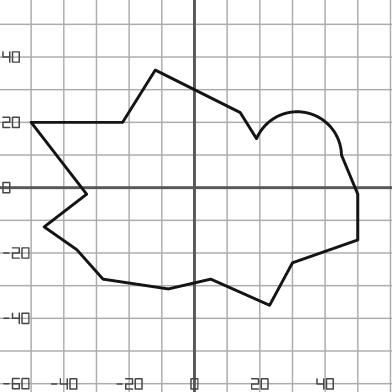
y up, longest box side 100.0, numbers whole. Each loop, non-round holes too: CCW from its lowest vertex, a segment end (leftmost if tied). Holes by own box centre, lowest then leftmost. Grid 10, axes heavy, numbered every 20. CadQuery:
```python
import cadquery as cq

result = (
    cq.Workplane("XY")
    .moveTo(23.0, -36.0)
    .lineTo(30.0, -23.0)
    .lineTo(50.0, -16.0)
    .lineTo(50.0, -2.0)
    .lineTo(45.0, 10.0)
    .threePointArc((34.0, 23.0), (19.0, 15.0))
    .lineTo(14.0, 23.0)
    .lineTo(-12.0, 36.0)
    .lineTo(-22.0, 20.0)
    .lineTo(-50.0, 20.0)
    .lineTo(-33.0, -2.0)
    .lineTo(-46.0, -12.0)
    .lineTo(-36.0, -19.0)
    .lineTo(-28.0, -28.0)
    .lineTo(-8.0, -31.0)
    .lineTo(5.0, -28.0)
    .close()
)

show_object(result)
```